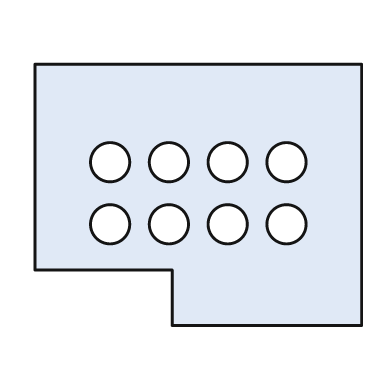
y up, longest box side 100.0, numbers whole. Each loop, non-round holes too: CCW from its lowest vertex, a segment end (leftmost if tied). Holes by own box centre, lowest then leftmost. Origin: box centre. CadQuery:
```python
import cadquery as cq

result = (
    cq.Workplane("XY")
    .moveTo(-8.0, -40.0)
    .lineTo(50.0, -40.0)
    .lineTo(50.0, 40.0)
    .lineTo(-50.0, 40.0)
    .lineTo(-50.0, -23.0)
    .lineTo(-8.0, -23.0)
    .close()
    .moveTo(-27.0, -9.0)
    .circle(6.0)
    .moveTo(-9.0, -9.0)
    .circle(6.0)
    .moveTo(9.0, -9.0)
    .circle(6.0)
    .moveTo(27.0, -9.0)
    .circle(6.0)
    .moveTo(-27.0, 10.0)
    .circle(6.0)
    .moveTo(-9.0, 10.0)
    .circle(6.0)
    .moveTo(9.0, 10.0)
    .circle(6.0)
    .moveTo(27.0, 10.0)
    .circle(6.0)
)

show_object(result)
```